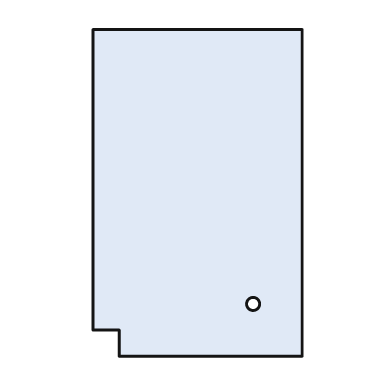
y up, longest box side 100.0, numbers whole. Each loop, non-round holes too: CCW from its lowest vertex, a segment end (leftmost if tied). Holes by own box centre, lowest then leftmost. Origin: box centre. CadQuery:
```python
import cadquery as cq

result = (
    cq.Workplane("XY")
    .moveTo(-24.0, -50.0)
    .lineTo(32.0, -50.0)
    .lineTo(32.0, 50.0)
    .lineTo(-32.0, 50.0)
    .lineTo(-32.0, -42.0)
    .lineTo(-24.0, -42.0)
    .close()
    .moveTo(17.0, -34.0)
    .circle(2.0)
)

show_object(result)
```